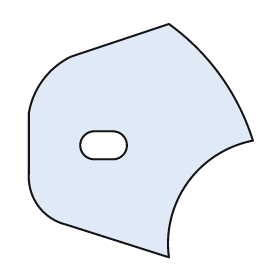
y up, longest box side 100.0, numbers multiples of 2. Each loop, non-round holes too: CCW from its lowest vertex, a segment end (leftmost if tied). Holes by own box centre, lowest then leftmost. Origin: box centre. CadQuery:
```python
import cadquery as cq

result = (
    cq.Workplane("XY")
    .moveTo(12.0, -50.0)
    .threePointArc((20.0, -18.0), (48.0, 0.0))
    .threePointArc((34.0, 28.0), (12.0, 50.0))
    .lineTo(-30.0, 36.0)
    .threePointArc((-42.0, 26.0), (-48.0, 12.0))
    .lineTo(-48.0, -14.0)
    .threePointArc((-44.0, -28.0), (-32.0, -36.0))
    .close()
    .moveTo(-20.0, -8.0)
    .lineTo(-12.0, -8.0)
    .threePointArc((-6.0, -2.0), (-12.0, 4.0))
    .lineTo(-20.0, 4.0)
    .threePointArc((-26.0, -2.0), (-20.0, -8.0))
    .close()
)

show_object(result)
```